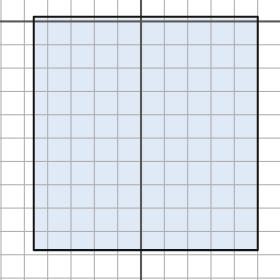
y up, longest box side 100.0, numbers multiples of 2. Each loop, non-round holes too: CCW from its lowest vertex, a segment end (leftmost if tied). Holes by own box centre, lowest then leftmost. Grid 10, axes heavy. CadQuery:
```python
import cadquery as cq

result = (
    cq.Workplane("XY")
    .moveTo(-46.0, -98.0)
    .lineTo(50.0, -98.0)
    .lineTo(50.0, 2.0)
    .lineTo(-46.0, 2.0)
    .close()
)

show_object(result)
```